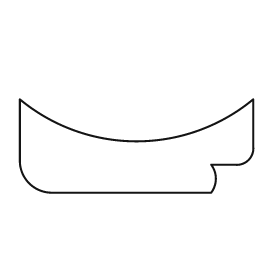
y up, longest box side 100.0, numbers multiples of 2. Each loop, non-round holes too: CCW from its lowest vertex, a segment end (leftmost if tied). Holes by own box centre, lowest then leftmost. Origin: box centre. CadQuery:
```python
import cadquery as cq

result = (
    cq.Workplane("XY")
    .moveTo(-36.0, -20.0)
    .lineTo(32.0, -20.0)
    .threePointArc((34.0, -14.0), (32.0, -8.0))
    .lineTo(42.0, -8.0)
    .threePointArc((48.0, -6.0), (50.0, 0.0))
    .lineTo(50.0, 20.0)
    .threePointArc((0.0, 2.0), (-50.0, 20.0))
    .lineTo(-50.0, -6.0)
    .threePointArc((-46.0, -16.0), (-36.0, -20.0))
    .close()
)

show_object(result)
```